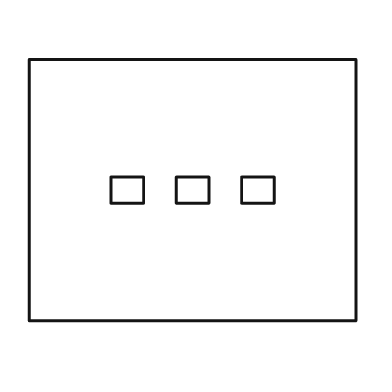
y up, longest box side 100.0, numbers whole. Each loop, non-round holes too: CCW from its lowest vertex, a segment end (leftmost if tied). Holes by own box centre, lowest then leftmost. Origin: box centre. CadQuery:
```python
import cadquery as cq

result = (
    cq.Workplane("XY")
    .moveTo(-50.0, -40.0)
    .lineTo(50.0, -40.0)
    .lineTo(50.0, 40.0)
    .lineTo(-50.0, 40.0)
    .close()
    .moveTo(-25.0, -4.0)
    .lineTo(-15.0, -4.0)
    .lineTo(-15.0, 4.0)
    .lineTo(-25.0, 4.0)
    .close()
    .moveTo(-5.0, -4.0)
    .lineTo(5.0, -4.0)
    .lineTo(5.0, 4.0)
    .lineTo(-5.0, 4.0)
    .close()
    .moveTo(15.0, -4.0)
    .lineTo(25.0, -4.0)
    .lineTo(25.0, 4.0)
    .lineTo(15.0, 4.0)
    .close()
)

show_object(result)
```